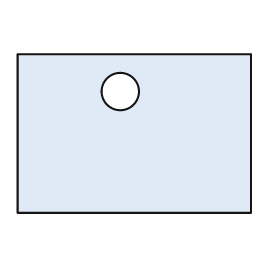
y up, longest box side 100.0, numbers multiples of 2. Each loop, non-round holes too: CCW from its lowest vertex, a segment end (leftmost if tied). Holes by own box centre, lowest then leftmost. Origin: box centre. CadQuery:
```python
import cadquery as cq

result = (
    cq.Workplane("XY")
    .moveTo(-50.0, -34.0)
    .lineTo(50.0, -34.0)
    .lineTo(50.0, 34.0)
    .lineTo(-50.0, 34.0)
    .close()
    .moveTo(-6.0, 18.0)
    .circle(8.0)
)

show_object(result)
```